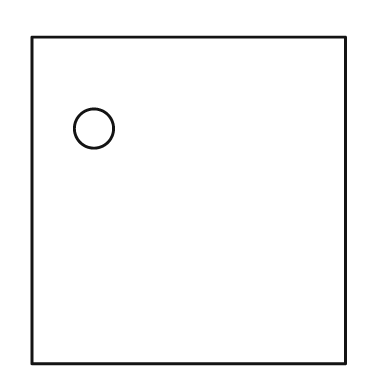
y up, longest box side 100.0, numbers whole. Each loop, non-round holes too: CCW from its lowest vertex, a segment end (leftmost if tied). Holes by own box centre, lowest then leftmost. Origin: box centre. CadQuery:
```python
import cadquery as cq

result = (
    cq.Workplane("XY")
    .moveTo(-48.0, -50.0)
    .lineTo(48.0, -50.0)
    .lineTo(48.0, 50.0)
    .lineTo(-48.0, 50.0)
    .close()
    .moveTo(-29.0, 22.0)
    .circle(6.0)
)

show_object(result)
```